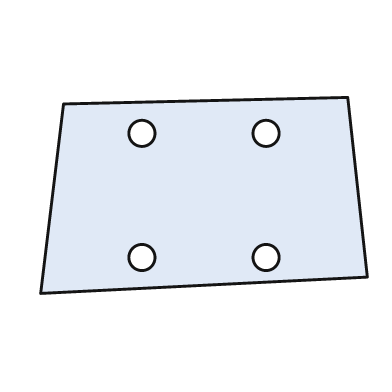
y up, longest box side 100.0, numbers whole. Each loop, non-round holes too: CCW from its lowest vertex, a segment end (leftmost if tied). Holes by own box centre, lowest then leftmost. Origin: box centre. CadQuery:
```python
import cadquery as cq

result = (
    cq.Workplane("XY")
    .moveTo(-50.0, -30.0)
    .lineTo(50.0, -25.0)
    .lineTo(44.0, 30.0)
    .lineTo(-43.0, 28.0)
    .close()
    .moveTo(-19.0, -19.0)
    .circle(4.0)
    .moveTo(19.0, -19.0)
    .circle(4.0)
    .moveTo(-19.0, 19.0)
    .circle(4.0)
    .moveTo(19.0, 19.0)
    .circle(4.0)
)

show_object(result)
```